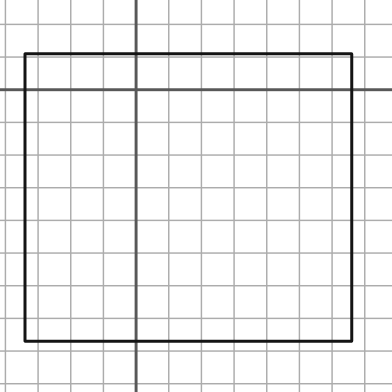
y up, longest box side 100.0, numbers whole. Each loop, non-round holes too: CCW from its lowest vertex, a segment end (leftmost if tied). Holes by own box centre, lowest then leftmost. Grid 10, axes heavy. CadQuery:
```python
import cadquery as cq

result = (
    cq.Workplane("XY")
    .moveTo(-34.0, -77.0)
    .lineTo(66.0, -77.0)
    .lineTo(66.0, 11.0)
    .lineTo(-34.0, 11.0)
    .close()
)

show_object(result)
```